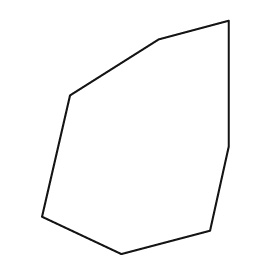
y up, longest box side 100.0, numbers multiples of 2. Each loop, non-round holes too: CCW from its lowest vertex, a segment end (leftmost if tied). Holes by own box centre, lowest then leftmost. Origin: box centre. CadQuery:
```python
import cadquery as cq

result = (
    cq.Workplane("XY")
    .moveTo(-6.0, -50.0)
    .lineTo(32.0, -40.0)
    .lineTo(40.0, -4.0)
    .lineTo(40.0, 50.0)
    .lineTo(10.0, 42.0)
    .lineTo(-28.0, 18.0)
    .lineTo(-40.0, -34.0)
    .close()
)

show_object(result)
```